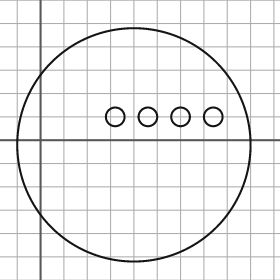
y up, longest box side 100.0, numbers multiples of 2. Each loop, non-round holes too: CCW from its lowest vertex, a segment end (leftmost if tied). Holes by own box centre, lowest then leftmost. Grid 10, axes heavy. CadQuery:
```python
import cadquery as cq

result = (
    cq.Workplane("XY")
    .moveTo(40.0, -2.0)
    .circle(50.0)
    .moveTo(32.0, 10.0)
    .circle(4.0)
    .moveTo(46.0, 10.0)
    .circle(4.0)
    .moveTo(60.0, 10.0)
    .circle(4.0)
    .moveTo(74.0, 10.0)
    .circle(4.0)
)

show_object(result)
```